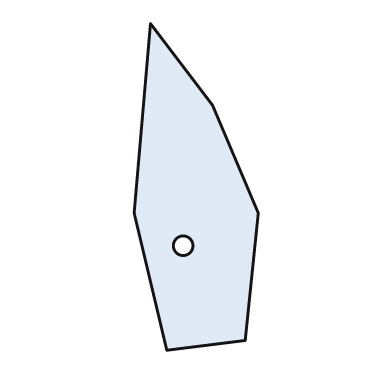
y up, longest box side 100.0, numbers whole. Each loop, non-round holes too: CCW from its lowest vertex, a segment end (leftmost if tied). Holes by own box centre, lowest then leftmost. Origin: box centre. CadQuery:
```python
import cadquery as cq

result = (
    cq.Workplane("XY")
    .moveTo(-9.0, -50.0)
    .lineTo(15.0, -47.0)
    .lineTo(19.0, -8.0)
    .lineTo(5.0, 25.0)
    .lineTo(-14.0, 50.0)
    .lineTo(-19.0, -8.0)
    .close()
    .moveTo(-4.0, -18.0)
    .circle(3.0)
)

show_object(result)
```